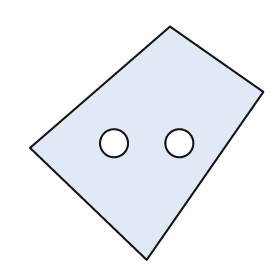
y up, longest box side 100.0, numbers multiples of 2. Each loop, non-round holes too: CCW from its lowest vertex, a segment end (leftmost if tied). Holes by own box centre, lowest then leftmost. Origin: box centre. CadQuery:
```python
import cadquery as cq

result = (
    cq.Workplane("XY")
    .moveTo(0.0, -50.0)
    .lineTo(50.0, 22.0)
    .lineTo(10.0, 50.0)
    .lineTo(-50.0, -2.0)
    .close()
    .moveTo(-14.0, 0.0)
    .circle(6.0)
    .moveTo(14.0, 0.0)
    .circle(6.0)
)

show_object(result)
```